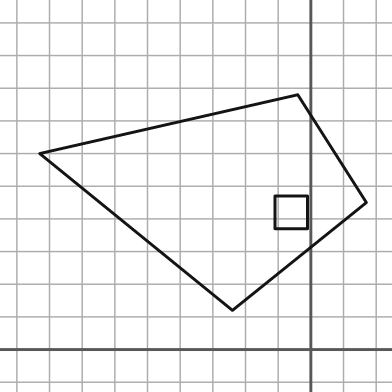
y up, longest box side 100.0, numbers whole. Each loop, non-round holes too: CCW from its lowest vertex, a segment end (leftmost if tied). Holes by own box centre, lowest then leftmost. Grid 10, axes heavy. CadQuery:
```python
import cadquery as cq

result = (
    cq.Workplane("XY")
    .moveTo(-24.0, 12.0)
    .lineTo(17.0, 45.0)
    .lineTo(-4.0, 78.0)
    .lineTo(-83.0, 60.0)
    .close()
    .moveTo(-11.0, 37.0)
    .lineTo(-1.0, 37.0)
    .lineTo(-1.0, 47.0)
    .lineTo(-11.0, 47.0)
    .close()
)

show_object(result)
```